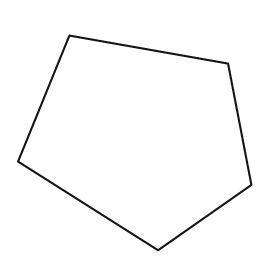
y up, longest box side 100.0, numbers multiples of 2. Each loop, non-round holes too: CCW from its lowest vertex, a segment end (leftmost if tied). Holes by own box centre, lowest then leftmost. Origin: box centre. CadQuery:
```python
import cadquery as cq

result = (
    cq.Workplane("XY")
    .moveTo(10.0, -46.0)
    .lineTo(50.0, -18.0)
    .lineTo(40.0, 34.0)
    .lineTo(-28.0, 46.0)
    .lineTo(-50.0, -8.0)
    .close()
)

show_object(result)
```